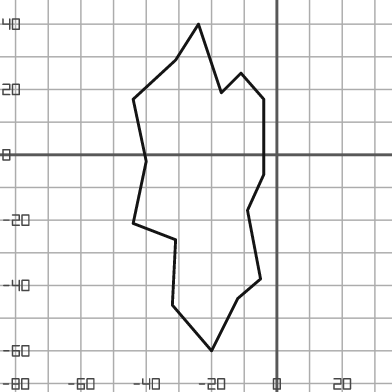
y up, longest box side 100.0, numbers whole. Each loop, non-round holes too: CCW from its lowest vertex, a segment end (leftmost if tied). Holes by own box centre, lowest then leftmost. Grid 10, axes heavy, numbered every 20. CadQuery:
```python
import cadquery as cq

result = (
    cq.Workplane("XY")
    .moveTo(-20.0, -60.0)
    .lineTo(-12.0, -44.0)
    .lineTo(-5.0, -38.0)
    .lineTo(-9.0, -17.0)
    .lineTo(-4.0, -6.0)
    .lineTo(-4.0, 17.0)
    .lineTo(-11.0, 25.0)
    .lineTo(-17.0, 19.0)
    .lineTo(-24.0, 40.0)
    .lineTo(-31.0, 29.0)
    .lineTo(-44.0, 17.0)
    .lineTo(-40.0, -2.0)
    .lineTo(-44.0, -21.0)
    .lineTo(-31.0, -26.0)
    .lineTo(-32.0, -46.0)
    .close()
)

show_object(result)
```